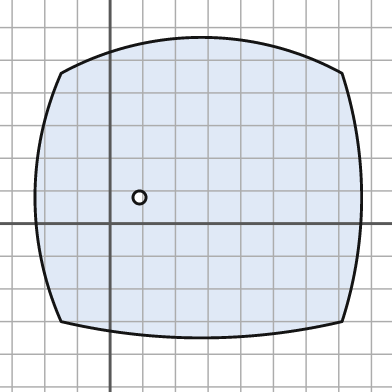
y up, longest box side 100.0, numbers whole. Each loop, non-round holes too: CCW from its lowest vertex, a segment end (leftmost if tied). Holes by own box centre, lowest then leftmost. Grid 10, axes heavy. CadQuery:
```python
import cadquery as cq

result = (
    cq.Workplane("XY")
    .moveTo(-15.0, -30.0)
    .threePointArc((28.0, -35.0), (71.0, -30.0))
    .threePointArc((77.0, 8.0), (71.0, 46.0))
    .threePointArc((28.0, 57.0), (-15.0, 46.0))
    .threePointArc((-23.0, 8.0), (-15.0, -30.0))
    .close()
    .moveTo(9.0, 8.0)
    .circle(2.0)
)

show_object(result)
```